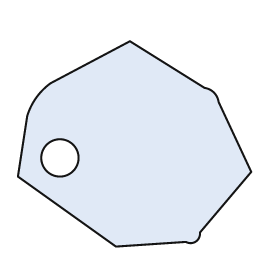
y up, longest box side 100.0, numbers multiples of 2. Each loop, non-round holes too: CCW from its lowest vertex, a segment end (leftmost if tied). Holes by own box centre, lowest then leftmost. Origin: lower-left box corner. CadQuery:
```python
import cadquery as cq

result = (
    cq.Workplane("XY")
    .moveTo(42.0, 0.0)
    .lineTo(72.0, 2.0)
    .threePointArc((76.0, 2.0), (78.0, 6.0))
    .lineTo(100.0, 32.0)
    .lineTo(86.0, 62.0)
    .threePointArc((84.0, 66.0), (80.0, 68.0))
    .lineTo(48.0, 88.0)
    .lineTo(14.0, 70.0)
    .threePointArc((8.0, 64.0), (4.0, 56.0))
    .lineTo(0.0, 30.0)
    .close()
    .moveTo(18.0, 38.0)
    .circle(8.0)
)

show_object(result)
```